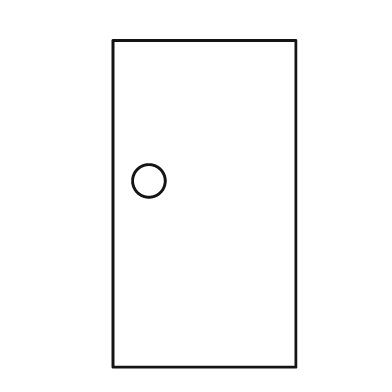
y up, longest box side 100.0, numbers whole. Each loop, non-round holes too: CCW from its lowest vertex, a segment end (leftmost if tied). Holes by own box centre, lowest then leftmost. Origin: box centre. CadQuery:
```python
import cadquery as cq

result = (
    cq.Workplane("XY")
    .moveTo(-28.0, -50.0)
    .lineTo(28.0, -50.0)
    .lineTo(28.0, 50.0)
    .lineTo(-28.0, 50.0)
    .close()
    .moveTo(-17.0, 7.0)
    .circle(5.0)
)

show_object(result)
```